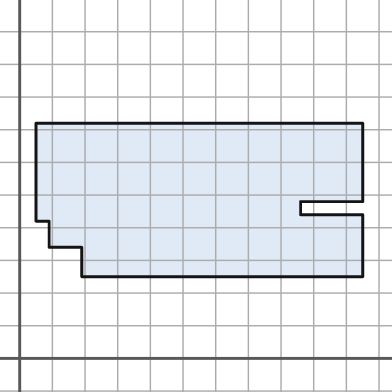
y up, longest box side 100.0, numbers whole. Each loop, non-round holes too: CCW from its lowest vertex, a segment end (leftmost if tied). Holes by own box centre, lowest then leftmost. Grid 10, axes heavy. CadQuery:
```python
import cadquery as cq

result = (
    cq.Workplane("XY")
    .moveTo(19.0, 25.0)
    .lineTo(105.0, 25.0)
    .lineTo(105.0, 44.0)
    .lineTo(86.0, 44.0)
    .lineTo(86.0, 48.0)
    .lineTo(105.0, 48.0)
    .lineTo(105.0, 72.0)
    .lineTo(5.0, 72.0)
    .lineTo(5.0, 42.0)
    .lineTo(9.0, 42.0)
    .lineTo(9.0, 34.0)
    .lineTo(19.0, 34.0)
    .close()
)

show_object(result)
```